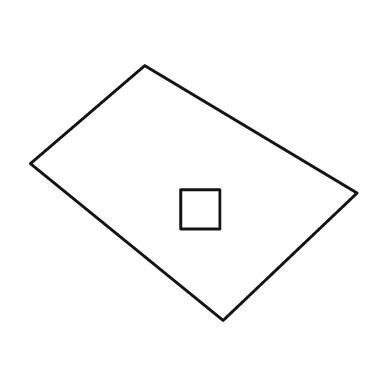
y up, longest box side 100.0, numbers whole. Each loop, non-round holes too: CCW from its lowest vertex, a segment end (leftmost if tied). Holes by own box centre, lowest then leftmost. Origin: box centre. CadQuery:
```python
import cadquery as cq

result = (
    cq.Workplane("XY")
    .moveTo(9.0, -39.0)
    .lineTo(50.0, 0.0)
    .lineTo(-15.0, 39.0)
    .lineTo(-50.0, 9.0)
    .close()
    .moveTo(-4.0, -11.0)
    .lineTo(8.0, -11.0)
    .lineTo(8.0, 1.0)
    .lineTo(-4.0, 1.0)
    .close()
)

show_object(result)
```